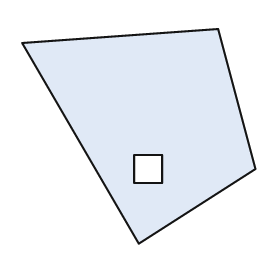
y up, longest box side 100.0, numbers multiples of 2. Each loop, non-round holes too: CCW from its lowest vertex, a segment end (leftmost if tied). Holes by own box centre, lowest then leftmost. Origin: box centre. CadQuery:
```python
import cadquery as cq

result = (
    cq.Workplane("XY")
    .moveTo(0.0, -46.0)
    .lineTo(50.0, -14.0)
    .lineTo(34.0, 46.0)
    .lineTo(-50.0, 40.0)
    .close()
    .moveTo(-2.0, -20.0)
    .lineTo(10.0, -20.0)
    .lineTo(10.0, -8.0)
    .lineTo(-2.0, -8.0)
    .close()
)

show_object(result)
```